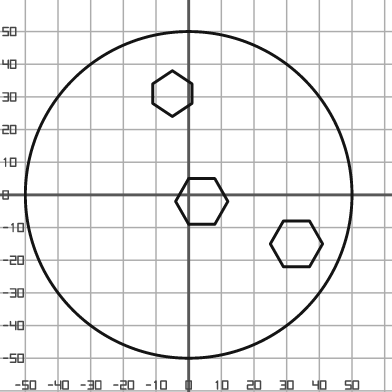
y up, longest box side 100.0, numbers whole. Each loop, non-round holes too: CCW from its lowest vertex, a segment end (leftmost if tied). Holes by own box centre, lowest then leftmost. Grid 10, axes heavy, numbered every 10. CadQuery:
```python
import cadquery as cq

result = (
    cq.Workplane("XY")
    .moveTo(0.0, 0.0)
    .circle(50.0)
    .moveTo(29.0, -22.0)
    .lineTo(37.0, -22.0)
    .lineTo(41.0, -15.0)
    .lineTo(37.0, -8.0)
    .lineTo(29.0, -8.0)
    .lineTo(25.0, -15.0)
    .close()
    .moveTo(0.0, -9.0)
    .lineTo(8.0, -9.0)
    .lineTo(12.0, -2.0)
    .lineTo(8.0, 5.0)
    .lineTo(0.0, 5.0)
    .lineTo(-4.0, -2.0)
    .close()
    .moveTo(-5.0, 24.0)
    .lineTo(1.0, 28.0)
    .lineTo(1.0, 34.0)
    .lineTo(-5.0, 38.0)
    .lineTo(-11.0, 34.0)
    .lineTo(-11.0, 28.0)
    .close()
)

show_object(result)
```